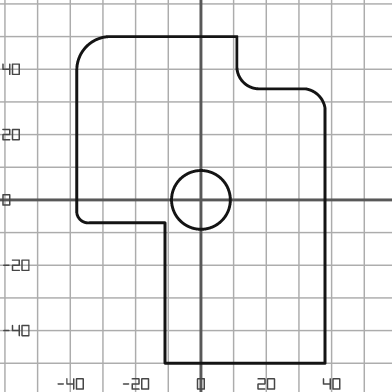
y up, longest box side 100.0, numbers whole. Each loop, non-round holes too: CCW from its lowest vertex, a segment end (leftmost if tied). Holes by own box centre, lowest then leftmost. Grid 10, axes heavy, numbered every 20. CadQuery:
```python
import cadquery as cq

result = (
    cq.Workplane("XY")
    .moveTo(-11.0, -50.0)
    .lineTo(38.0, -50.0)
    .lineTo(38.0, 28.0)
    .threePointArc((36.0, 32.0), (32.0, 34.0))
    .lineTo(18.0, 34.0)
    .threePointArc((13.0, 36.0), (11.0, 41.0))
    .lineTo(11.0, 50.0)
    .lineTo(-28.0, 50.0)
    .threePointArc((-35.0, 47.0), (-38.0, 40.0))
    .lineTo(-38.0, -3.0)
    .threePointArc((-37.0, -6.0), (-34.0, -7.0))
    .lineTo(-11.0, -7.0)
    .close()
    .moveTo(0.0, 0.0)
    .circle(9.0)
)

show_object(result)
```